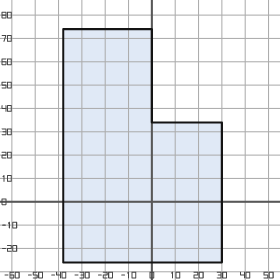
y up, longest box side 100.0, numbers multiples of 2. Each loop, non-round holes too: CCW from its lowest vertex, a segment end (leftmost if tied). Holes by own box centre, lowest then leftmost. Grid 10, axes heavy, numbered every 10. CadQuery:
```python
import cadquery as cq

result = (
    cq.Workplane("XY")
    .moveTo(-38.0, -26.0)
    .lineTo(30.0, -26.0)
    .lineTo(30.0, 34.0)
    .lineTo(0.0, 34.0)
    .lineTo(0.0, 74.0)
    .lineTo(-38.0, 74.0)
    .close()
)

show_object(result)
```